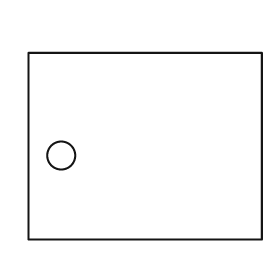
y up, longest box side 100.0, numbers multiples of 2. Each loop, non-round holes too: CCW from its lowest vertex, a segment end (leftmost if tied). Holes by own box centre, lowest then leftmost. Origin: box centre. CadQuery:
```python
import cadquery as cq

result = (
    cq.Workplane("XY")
    .moveTo(-50.0, -40.0)
    .lineTo(50.0, -40.0)
    .lineTo(50.0, 40.0)
    .lineTo(-50.0, 40.0)
    .close()
    .moveTo(-36.0, -4.0)
    .circle(6.0)
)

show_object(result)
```